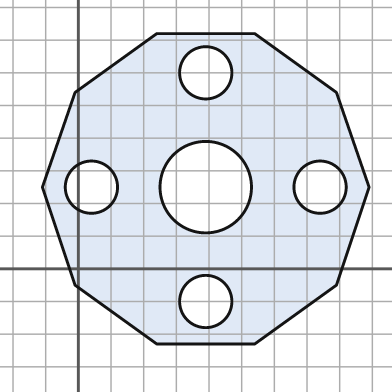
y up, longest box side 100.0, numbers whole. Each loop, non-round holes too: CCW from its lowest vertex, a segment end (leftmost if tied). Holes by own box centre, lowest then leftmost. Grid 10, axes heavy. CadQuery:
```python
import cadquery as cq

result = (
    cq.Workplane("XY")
    .moveTo(24.0, -23.0)
    .lineTo(54.0, -23.0)
    .lineTo(79.0, -5.0)
    .lineTo(89.0, 25.0)
    .lineTo(79.0, 54.0)
    .lineTo(54.0, 72.0)
    .lineTo(24.0, 72.0)
    .lineTo(-1.0, 54.0)
    .lineTo(-11.0, 25.0)
    .lineTo(-1.0, -5.0)
    .close()
    .moveTo(39.0, -10.0)
    .circle(8.0)
    .moveTo(4.0, 25.0)
    .circle(8.0)
    .moveTo(39.0, 25.0)
    .circle(14.0)
    .moveTo(74.0, 25.0)
    .circle(8.0)
    .moveTo(39.0, 60.0)
    .circle(8.0)
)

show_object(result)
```